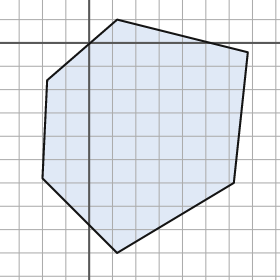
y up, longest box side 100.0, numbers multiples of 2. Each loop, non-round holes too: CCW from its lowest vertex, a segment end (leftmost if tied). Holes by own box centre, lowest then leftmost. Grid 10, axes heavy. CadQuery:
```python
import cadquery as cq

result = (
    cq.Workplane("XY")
    .moveTo(12.0, -90.0)
    .lineTo(62.0, -60.0)
    .lineTo(68.0, -4.0)
    .lineTo(12.0, 10.0)
    .lineTo(-18.0, -16.0)
    .lineTo(-20.0, -58.0)
    .close()
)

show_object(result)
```